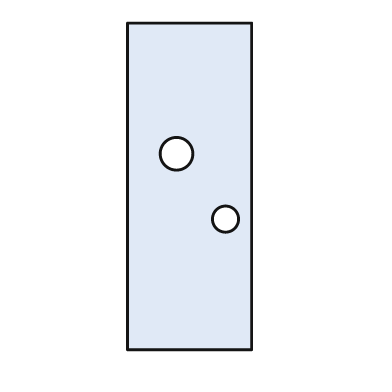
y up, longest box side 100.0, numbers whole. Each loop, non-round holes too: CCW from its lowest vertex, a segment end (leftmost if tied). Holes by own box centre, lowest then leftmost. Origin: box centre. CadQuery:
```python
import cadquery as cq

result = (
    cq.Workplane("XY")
    .moveTo(-19.0, -50.0)
    .lineTo(19.0, -50.0)
    .lineTo(19.0, 50.0)
    .lineTo(-19.0, 50.0)
    .close()
    .moveTo(11.0, -10.0)
    .circle(4.0)
    .moveTo(-4.0, 10.0)
    .circle(5.0)
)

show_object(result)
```